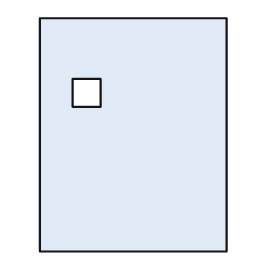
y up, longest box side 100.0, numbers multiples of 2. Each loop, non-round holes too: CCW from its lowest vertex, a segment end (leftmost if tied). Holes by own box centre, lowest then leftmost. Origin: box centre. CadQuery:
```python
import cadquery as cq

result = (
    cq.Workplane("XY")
    .moveTo(-40.0, -50.0)
    .lineTo(40.0, -50.0)
    .lineTo(40.0, 50.0)
    .lineTo(-40.0, 50.0)
    .close()
    .moveTo(-26.0, 12.0)
    .lineTo(-14.0, 12.0)
    .lineTo(-14.0, 24.0)
    .lineTo(-26.0, 24.0)
    .close()
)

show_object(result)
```